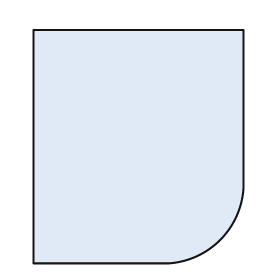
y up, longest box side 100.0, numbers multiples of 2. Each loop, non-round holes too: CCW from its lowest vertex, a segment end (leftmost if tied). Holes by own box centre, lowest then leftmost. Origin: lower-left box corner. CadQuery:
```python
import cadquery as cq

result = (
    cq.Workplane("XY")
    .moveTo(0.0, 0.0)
    .lineTo(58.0, 0.0)
    .threePointArc((80.0, 10.0), (90.0, 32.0))
    .lineTo(90.0, 100.0)
    .lineTo(0.0, 100.0)
    .close()
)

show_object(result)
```